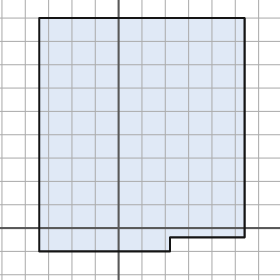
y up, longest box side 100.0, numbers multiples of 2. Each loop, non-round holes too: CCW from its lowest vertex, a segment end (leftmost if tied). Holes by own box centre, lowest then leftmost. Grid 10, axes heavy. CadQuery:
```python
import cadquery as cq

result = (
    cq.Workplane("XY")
    .moveTo(-34.0, -10.0)
    .lineTo(22.0, -10.0)
    .lineTo(22.0, -4.0)
    .lineTo(54.0, -4.0)
    .lineTo(54.0, 90.0)
    .lineTo(-34.0, 90.0)
    .close()
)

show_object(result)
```